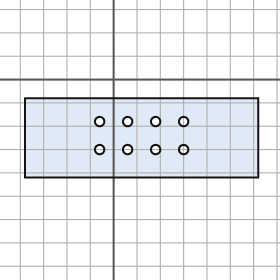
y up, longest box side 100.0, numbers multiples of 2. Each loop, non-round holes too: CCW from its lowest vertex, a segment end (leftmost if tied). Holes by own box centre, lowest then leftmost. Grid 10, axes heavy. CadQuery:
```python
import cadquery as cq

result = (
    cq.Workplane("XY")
    .moveTo(-38.0, -42.0)
    .lineTo(62.0, -42.0)
    .lineTo(62.0, -8.0)
    .lineTo(-38.0, -8.0)
    .close()
    .moveTo(-6.0, -30.0)
    .circle(2.0)
    .moveTo(6.0, -30.0)
    .circle(2.0)
    .moveTo(18.0, -30.0)
    .circle(2.0)
    .moveTo(30.0, -30.0)
    .circle(2.0)
    .moveTo(-6.0, -18.0)
    .circle(2.0)
    .moveTo(6.0, -18.0)
    .circle(2.0)
    .moveTo(18.0, -18.0)
    .circle(2.0)
    .moveTo(30.0, -18.0)
    .circle(2.0)
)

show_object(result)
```